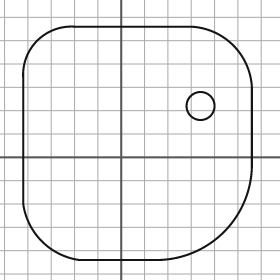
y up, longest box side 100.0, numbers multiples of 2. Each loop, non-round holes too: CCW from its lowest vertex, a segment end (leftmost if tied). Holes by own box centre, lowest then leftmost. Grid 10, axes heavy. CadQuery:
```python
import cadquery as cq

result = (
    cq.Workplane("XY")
    .moveTo(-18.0, -44.0)
    .lineTo(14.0, -44.0)
    .threePointArc((44.0, -32.0), (56.0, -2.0))
    .lineTo(56.0, 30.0)
    .threePointArc((48.0, 48.0), (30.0, 56.0))
    .lineTo(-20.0, 56.0)
    .threePointArc((-36.0, 50.0), (-42.0, 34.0))
    .lineTo(-42.0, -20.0)
    .threePointArc((-34.0, -36.0), (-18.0, -44.0))
    .close()
    .moveTo(34.0, 22.0)
    .circle(6.0)
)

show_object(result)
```